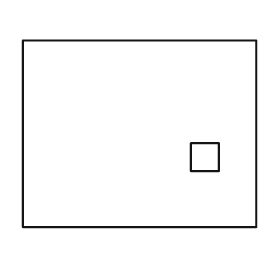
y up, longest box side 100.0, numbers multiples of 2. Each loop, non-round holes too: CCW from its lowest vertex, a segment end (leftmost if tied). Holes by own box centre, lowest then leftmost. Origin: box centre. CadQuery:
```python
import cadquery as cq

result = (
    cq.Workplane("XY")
    .moveTo(-50.0, -40.0)
    .lineTo(50.0, -40.0)
    .lineTo(50.0, 40.0)
    .lineTo(-50.0, 40.0)
    .close()
    .moveTo(22.0, -16.0)
    .lineTo(34.0, -16.0)
    .lineTo(34.0, -4.0)
    .lineTo(22.0, -4.0)
    .close()
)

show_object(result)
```